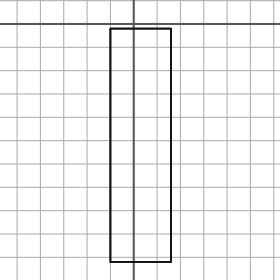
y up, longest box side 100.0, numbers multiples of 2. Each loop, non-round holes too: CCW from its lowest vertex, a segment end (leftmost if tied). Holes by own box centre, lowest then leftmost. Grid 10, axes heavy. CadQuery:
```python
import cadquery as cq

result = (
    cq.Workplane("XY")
    .moveTo(-10.0, -102.0)
    .lineTo(16.0, -102.0)
    .lineTo(16.0, -2.0)
    .lineTo(-10.0, -2.0)
    .close()
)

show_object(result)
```